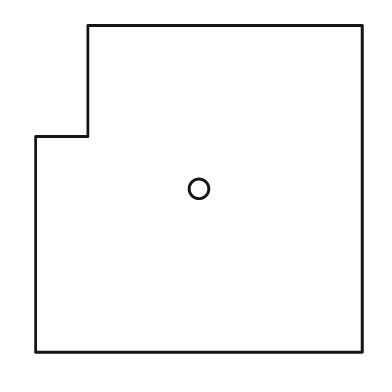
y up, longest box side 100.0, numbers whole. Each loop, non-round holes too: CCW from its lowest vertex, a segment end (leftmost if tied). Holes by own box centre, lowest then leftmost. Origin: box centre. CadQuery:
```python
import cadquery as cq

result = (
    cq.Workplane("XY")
    .moveTo(-50.0, -50.0)
    .lineTo(50.0, -50.0)
    .lineTo(50.0, 50.0)
    .lineTo(-34.0, 50.0)
    .lineTo(-34.0, 16.0)
    .lineTo(-50.0, 16.0)
    .close()
    .moveTo(0.0, 0.0)
    .circle(3.0)
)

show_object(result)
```